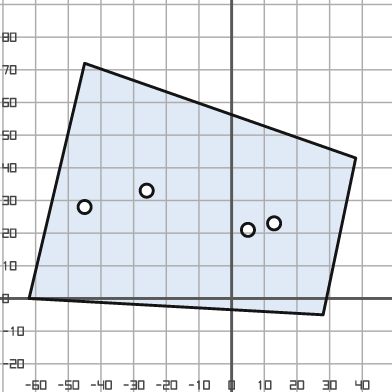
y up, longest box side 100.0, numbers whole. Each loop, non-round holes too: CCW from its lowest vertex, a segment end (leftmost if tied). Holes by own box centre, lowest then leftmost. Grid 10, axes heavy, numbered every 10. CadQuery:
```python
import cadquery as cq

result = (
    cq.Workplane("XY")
    .moveTo(28.0, -5.0)
    .lineTo(38.0, 43.0)
    .lineTo(-45.0, 72.0)
    .lineTo(-62.0, 0.0)
    .close()
    .moveTo(5.0, 21.0)
    .circle(2.0)
    .moveTo(13.0, 23.0)
    .circle(2.0)
    .moveTo(-45.0, 28.0)
    .circle(2.0)
    .moveTo(-26.0, 33.0)
    .circle(2.0)
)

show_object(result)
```